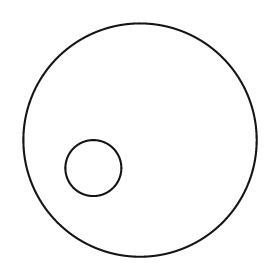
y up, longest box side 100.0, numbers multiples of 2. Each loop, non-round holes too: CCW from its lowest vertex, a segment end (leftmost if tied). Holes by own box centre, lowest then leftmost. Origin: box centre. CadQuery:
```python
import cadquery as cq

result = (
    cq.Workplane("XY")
    .moveTo(0.0, 0.0)
    .circle(50.0)
    .moveTo(-20.0, -12.0)
    .circle(12.0)
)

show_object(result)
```